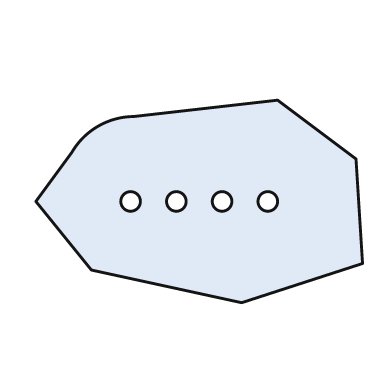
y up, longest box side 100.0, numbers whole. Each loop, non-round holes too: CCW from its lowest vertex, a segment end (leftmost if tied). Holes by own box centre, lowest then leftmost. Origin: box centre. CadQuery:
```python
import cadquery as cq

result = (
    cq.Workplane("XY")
    .moveTo(13.0, -31.0)
    .lineTo(50.0, -19.0)
    .lineTo(48.0, 13.0)
    .lineTo(24.0, 31.0)
    .lineTo(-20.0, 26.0)
    .threePointArc((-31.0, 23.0), (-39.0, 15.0))
    .lineTo(-50.0, 0.0)
    .lineTo(-33.0, -21.0)
    .close()
    .moveTo(-21.0, 0.0)
    .circle(3.0)
    .moveTo(-7.0, 0.0)
    .circle(3.0)
    .moveTo(7.0, 0.0)
    .circle(3.0)
    .moveTo(21.0, 0.0)
    .circle(3.0)
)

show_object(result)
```